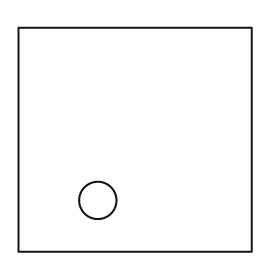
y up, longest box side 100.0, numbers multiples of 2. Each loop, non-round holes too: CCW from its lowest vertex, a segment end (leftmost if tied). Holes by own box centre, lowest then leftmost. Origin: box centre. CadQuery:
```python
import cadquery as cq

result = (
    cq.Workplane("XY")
    .moveTo(-50.0, -48.0)
    .lineTo(50.0, -48.0)
    .lineTo(50.0, 48.0)
    .lineTo(-50.0, 48.0)
    .close()
    .moveTo(-16.0, -26.0)
    .circle(8.0)
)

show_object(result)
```